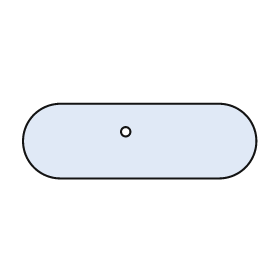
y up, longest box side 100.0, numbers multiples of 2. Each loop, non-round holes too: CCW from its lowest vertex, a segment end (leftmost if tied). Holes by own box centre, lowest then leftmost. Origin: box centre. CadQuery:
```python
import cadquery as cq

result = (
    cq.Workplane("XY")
    .moveTo(-34.0, -16.0)
    .lineTo(34.0, -16.0)
    .threePointArc((50.0, 0.0), (34.0, 16.0))
    .lineTo(-34.0, 16.0)
    .threePointArc((-50.0, 0.0), (-34.0, -16.0))
    .close()
    .moveTo(-6.0, 4.0)
    .circle(2.0)
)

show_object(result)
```